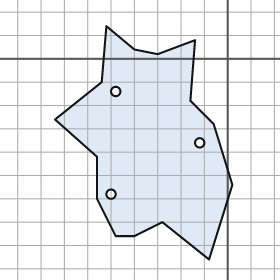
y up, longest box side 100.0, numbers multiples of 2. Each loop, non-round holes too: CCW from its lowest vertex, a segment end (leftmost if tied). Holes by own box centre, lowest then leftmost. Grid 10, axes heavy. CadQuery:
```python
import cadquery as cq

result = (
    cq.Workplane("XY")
    .moveTo(-8.0, -86.0)
    .lineTo(2.0, -54.0)
    .lineTo(-6.0, -28.0)
    .lineTo(-16.0, -18.0)
    .lineTo(-14.0, 8.0)
    .lineTo(-30.0, 2.0)
    .lineTo(-40.0, 4.0)
    .lineTo(-52.0, 14.0)
    .lineTo(-54.0, -10.0)
    .lineTo(-74.0, -26.0)
    .lineTo(-56.0, -42.0)
    .lineTo(-56.0, -60.0)
    .lineTo(-48.0, -76.0)
    .lineTo(-40.0, -76.0)
    .lineTo(-28.0, -70.0)
    .close()
    .moveTo(-50.0, -58.0)
    .circle(2.0)
    .moveTo(-12.0, -36.0)
    .circle(2.0)
    .moveTo(-48.0, -14.0)
    .circle(2.0)
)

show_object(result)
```